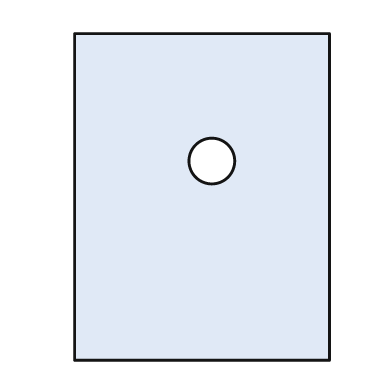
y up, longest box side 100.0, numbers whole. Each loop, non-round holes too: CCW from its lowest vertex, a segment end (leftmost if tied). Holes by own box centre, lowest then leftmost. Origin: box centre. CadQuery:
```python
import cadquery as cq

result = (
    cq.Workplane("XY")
    .moveTo(-39.0, -50.0)
    .lineTo(39.0, -50.0)
    .lineTo(39.0, 50.0)
    .lineTo(-39.0, 50.0)
    .close()
    .moveTo(3.0, 11.0)
    .circle(7.0)
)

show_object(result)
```